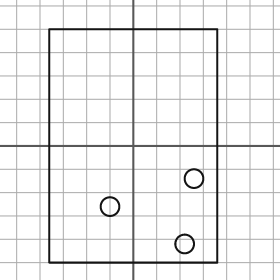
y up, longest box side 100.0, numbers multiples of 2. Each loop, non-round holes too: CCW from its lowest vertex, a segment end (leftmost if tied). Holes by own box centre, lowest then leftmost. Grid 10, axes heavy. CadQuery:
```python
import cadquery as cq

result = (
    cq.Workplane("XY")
    .moveTo(-36.0, -50.0)
    .lineTo(36.0, -50.0)
    .lineTo(36.0, 50.0)
    .lineTo(-36.0, 50.0)
    .close()
    .moveTo(22.0, -42.0)
    .circle(4.0)
    .moveTo(-10.0, -26.0)
    .circle(4.0)
    .moveTo(26.0, -14.0)
    .circle(4.0)
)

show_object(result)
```